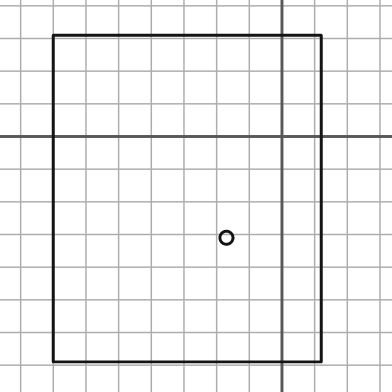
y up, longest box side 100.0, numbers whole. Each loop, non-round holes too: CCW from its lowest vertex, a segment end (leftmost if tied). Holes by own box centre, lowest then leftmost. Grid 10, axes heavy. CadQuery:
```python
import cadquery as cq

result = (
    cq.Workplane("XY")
    .moveTo(-70.0, -69.0)
    .lineTo(12.0, -69.0)
    .lineTo(12.0, 31.0)
    .lineTo(-70.0, 31.0)
    .close()
    .moveTo(-17.0, -31.0)
    .circle(2.0)
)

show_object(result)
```